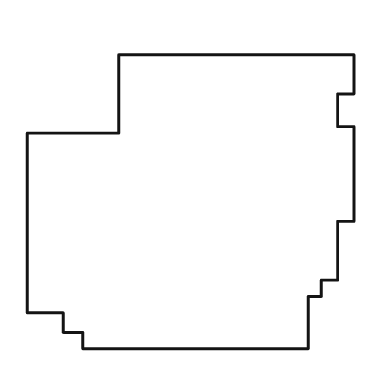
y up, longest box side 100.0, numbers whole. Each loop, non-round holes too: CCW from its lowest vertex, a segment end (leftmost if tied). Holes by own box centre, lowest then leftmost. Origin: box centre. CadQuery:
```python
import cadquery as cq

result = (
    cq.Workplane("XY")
    .moveTo(-33.0, -45.0)
    .lineTo(36.0, -45.0)
    .lineTo(36.0, -29.0)
    .lineTo(40.0, -29.0)
    .lineTo(40.0, -24.0)
    .lineTo(45.0, -24.0)
    .lineTo(45.0, -6.0)
    .lineTo(50.0, -6.0)
    .lineTo(50.0, 23.0)
    .lineTo(45.0, 23.0)
    .lineTo(45.0, 33.0)
    .lineTo(50.0, 33.0)
    .lineTo(50.0, 45.0)
    .lineTo(-22.0, 45.0)
    .lineTo(-22.0, 21.0)
    .lineTo(-50.0, 21.0)
    .lineTo(-50.0, -34.0)
    .lineTo(-39.0, -34.0)
    .lineTo(-39.0, -40.0)
    .lineTo(-33.0, -40.0)
    .close()
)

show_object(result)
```